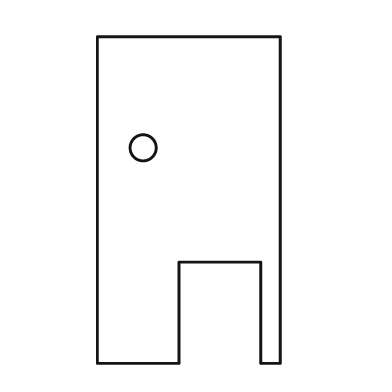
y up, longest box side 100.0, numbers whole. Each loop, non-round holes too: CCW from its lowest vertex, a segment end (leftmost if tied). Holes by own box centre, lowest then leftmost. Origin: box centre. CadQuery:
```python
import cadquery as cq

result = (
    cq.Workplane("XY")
    .moveTo(-28.0, -50.0)
    .lineTo(-3.0, -50.0)
    .lineTo(-3.0, -19.0)
    .lineTo(22.0, -19.0)
    .lineTo(22.0, -50.0)
    .lineTo(28.0, -50.0)
    .lineTo(28.0, 50.0)
    .lineTo(-28.0, 50.0)
    .close()
    .moveTo(-14.0, 16.0)
    .circle(4.0)
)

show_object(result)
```